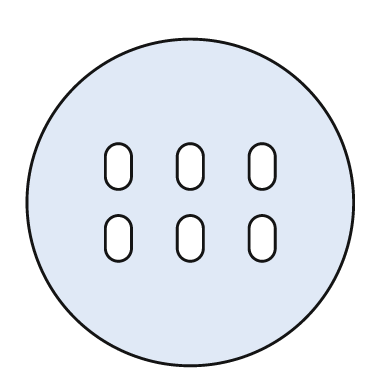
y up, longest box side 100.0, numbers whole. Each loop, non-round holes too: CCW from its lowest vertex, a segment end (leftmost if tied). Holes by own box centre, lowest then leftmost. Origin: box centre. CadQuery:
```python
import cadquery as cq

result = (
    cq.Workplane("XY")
    .moveTo(0.0, 0.0)
    .circle(50.0)
    .moveTo(-26.0, -14.0)
    .threePointArc((-22.0, -18.0), (-18.0, -14.0))
    .lineTo(-18.0, -8.0)
    .threePointArc((-22.0, -4.0), (-26.0, -8.0))
    .close()
    .moveTo(-4.0, -14.0)
    .threePointArc((0.0, -18.0), (4.0, -14.0))
    .lineTo(4.0, -8.0)
    .threePointArc((0.0, -4.0), (-4.0, -8.0))
    .close()
    .moveTo(18.0, -14.0)
    .threePointArc((22.0, -18.0), (26.0, -14.0))
    .lineTo(26.0, -8.0)
    .threePointArc((22.0, -4.0), (18.0, -8.0))
    .close()
    .moveTo(-26.0, 8.0)
    .threePointArc((-22.0, 4.0), (-18.0, 8.0))
    .lineTo(-18.0, 14.0)
    .threePointArc((-22.0, 18.0), (-26.0, 14.0))
    .close()
    .moveTo(-4.0, 8.0)
    .threePointArc((0.0, 4.0), (4.0, 8.0))
    .lineTo(4.0, 14.0)
    .threePointArc((0.0, 18.0), (-4.0, 14.0))
    .close()
    .moveTo(18.0, 8.0)
    .threePointArc((22.0, 4.0), (26.0, 8.0))
    .lineTo(26.0, 14.0)
    .threePointArc((22.0, 18.0), (18.0, 14.0))
    .close()
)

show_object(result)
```